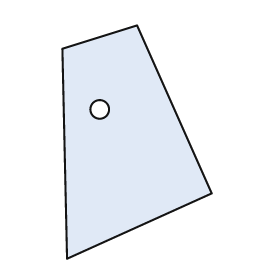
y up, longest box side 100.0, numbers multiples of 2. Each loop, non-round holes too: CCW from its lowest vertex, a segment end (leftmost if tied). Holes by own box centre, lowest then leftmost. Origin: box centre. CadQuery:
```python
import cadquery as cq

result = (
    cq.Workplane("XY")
    .moveTo(-30.0, -50.0)
    .lineTo(32.0, -22.0)
    .lineTo(0.0, 50.0)
    .lineTo(-32.0, 40.0)
    .close()
    .moveTo(-16.0, 14.0)
    .circle(4.0)
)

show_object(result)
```